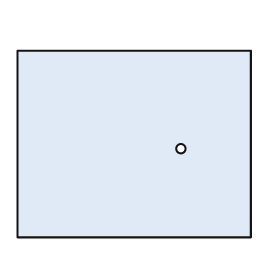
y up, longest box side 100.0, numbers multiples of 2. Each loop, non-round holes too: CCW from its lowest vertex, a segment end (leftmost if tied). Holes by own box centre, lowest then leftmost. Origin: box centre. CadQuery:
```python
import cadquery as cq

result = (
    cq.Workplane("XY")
    .moveTo(-50.0, -40.0)
    .lineTo(50.0, -40.0)
    .lineTo(50.0, 40.0)
    .lineTo(-50.0, 40.0)
    .close()
    .moveTo(20.0, -2.0)
    .circle(2.0)
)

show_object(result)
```